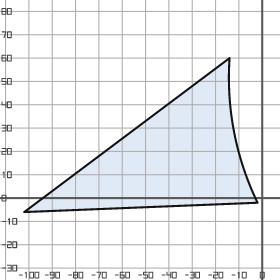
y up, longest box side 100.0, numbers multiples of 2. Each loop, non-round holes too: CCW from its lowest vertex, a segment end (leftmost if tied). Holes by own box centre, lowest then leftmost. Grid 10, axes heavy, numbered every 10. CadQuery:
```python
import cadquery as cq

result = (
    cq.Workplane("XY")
    .moveTo(-102.0, -6.0)
    .lineTo(-2.0, -2.0)
    .threePointArc((-12.0, 28.0), (-14.0, 60.0))
    .close()
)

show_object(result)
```